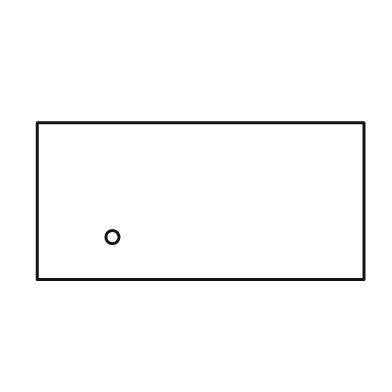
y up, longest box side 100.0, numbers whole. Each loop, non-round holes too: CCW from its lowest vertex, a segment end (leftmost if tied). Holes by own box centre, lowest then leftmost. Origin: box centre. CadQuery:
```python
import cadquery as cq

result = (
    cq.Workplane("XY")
    .moveTo(-50.0, -24.0)
    .lineTo(50.0, -24.0)
    .lineTo(50.0, 24.0)
    .lineTo(-50.0, 24.0)
    .close()
    .moveTo(-27.0, -11.0)
    .circle(2.0)
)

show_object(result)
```